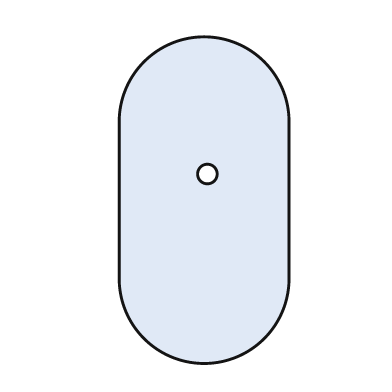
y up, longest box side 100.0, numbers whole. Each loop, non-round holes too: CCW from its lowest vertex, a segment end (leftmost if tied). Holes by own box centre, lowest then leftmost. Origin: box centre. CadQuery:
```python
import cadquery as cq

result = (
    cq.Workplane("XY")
    .moveTo(-26.0, -24.0)
    .threePointArc((0.0, -50.0), (26.0, -24.0))
    .lineTo(26.0, 24.0)
    .threePointArc((0.0, 50.0), (-26.0, 24.0))
    .close()
    .moveTo(1.0, 8.0)
    .circle(3.0)
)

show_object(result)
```